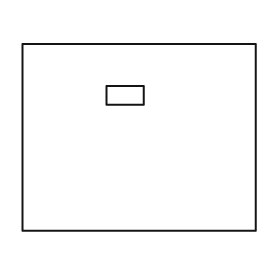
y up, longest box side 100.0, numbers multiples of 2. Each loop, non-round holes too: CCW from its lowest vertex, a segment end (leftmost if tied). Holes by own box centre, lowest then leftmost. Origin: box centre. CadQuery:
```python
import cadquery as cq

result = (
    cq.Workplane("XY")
    .moveTo(-50.0, -40.0)
    .lineTo(50.0, -40.0)
    .lineTo(50.0, 40.0)
    .lineTo(-50.0, 40.0)
    .close()
    .moveTo(-14.0, 14.0)
    .lineTo(2.0, 14.0)
    .lineTo(2.0, 22.0)
    .lineTo(-14.0, 22.0)
    .close()
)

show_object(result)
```